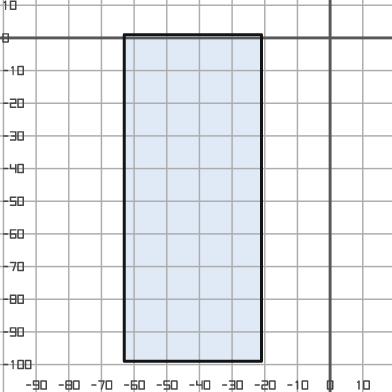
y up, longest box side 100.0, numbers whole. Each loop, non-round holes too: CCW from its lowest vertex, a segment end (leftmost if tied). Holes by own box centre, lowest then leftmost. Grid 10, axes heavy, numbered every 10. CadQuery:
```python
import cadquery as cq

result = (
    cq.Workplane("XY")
    .moveTo(-63.0, -99.0)
    .lineTo(-21.0, -99.0)
    .lineTo(-21.0, 1.0)
    .lineTo(-63.0, 1.0)
    .close()
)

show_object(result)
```